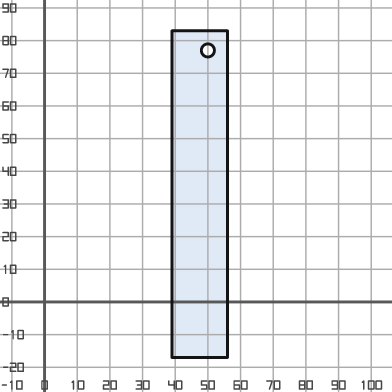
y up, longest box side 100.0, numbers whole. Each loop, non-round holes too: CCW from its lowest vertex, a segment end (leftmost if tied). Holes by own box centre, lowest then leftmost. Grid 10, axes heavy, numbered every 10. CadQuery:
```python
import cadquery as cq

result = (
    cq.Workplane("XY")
    .moveTo(39.0, -17.0)
    .lineTo(56.0, -17.0)
    .lineTo(56.0, 83.0)
    .lineTo(39.0, 83.0)
    .close()
    .moveTo(50.0, 77.0)
    .circle(2.0)
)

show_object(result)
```